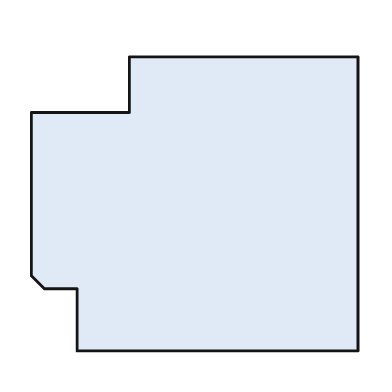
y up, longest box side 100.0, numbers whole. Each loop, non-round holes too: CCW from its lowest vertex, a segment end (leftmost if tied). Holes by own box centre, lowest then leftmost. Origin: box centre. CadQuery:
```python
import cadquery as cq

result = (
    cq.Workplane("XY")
    .moveTo(-36.0, -45.0)
    .lineTo(50.0, -45.0)
    .lineTo(50.0, 45.0)
    .lineTo(-20.0, 45.0)
    .lineTo(-20.0, 28.0)
    .lineTo(-50.0, 28.0)
    .lineTo(-50.0, -22.0)
    .lineTo(-46.0, -26.0)
    .lineTo(-36.0, -26.0)
    .close()
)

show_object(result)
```